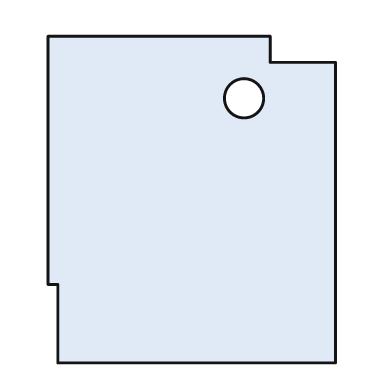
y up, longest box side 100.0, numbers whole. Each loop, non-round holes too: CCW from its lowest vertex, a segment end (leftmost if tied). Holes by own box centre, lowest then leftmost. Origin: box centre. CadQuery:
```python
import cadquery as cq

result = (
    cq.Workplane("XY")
    .moveTo(-41.0, -50.0)
    .lineTo(44.0, -50.0)
    .lineTo(44.0, 42.0)
    .lineTo(24.0, 42.0)
    .lineTo(24.0, 50.0)
    .lineTo(-44.0, 50.0)
    .lineTo(-44.0, -26.0)
    .lineTo(-41.0, -26.0)
    .close()
    .moveTo(16.0, 31.0)
    .circle(6.0)
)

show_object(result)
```